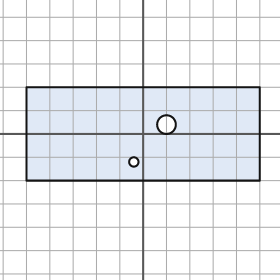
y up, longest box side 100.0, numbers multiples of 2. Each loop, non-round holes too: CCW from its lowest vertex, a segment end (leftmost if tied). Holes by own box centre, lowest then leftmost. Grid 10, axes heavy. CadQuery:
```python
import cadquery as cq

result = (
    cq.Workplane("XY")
    .moveTo(-50.0, -20.0)
    .lineTo(50.0, -20.0)
    .lineTo(50.0, 20.0)
    .lineTo(-50.0, 20.0)
    .close()
    .moveTo(-4.0, -12.0)
    .circle(2.0)
    .moveTo(10.0, 4.0)
    .circle(4.0)
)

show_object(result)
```